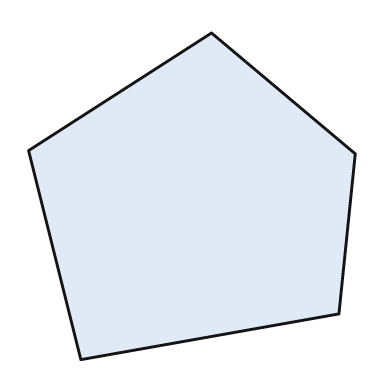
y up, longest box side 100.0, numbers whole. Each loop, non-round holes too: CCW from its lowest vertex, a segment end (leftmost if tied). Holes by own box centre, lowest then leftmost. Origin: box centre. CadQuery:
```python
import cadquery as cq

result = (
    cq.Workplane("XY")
    .moveTo(-34.0, -50.0)
    .lineTo(45.0, -36.0)
    .lineTo(50.0, 13.0)
    .lineTo(6.0, 50.0)
    .lineTo(-50.0, 14.0)
    .close()
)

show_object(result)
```